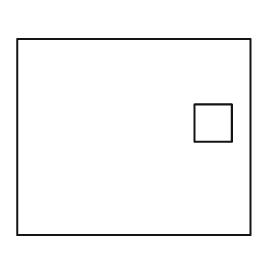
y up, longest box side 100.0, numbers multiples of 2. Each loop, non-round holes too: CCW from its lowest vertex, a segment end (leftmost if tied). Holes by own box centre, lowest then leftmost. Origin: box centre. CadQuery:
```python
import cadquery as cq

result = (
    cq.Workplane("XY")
    .moveTo(-50.0, -42.0)
    .lineTo(50.0, -42.0)
    .lineTo(50.0, 42.0)
    .lineTo(-50.0, 42.0)
    .close()
    .moveTo(26.0, -2.0)
    .lineTo(42.0, -2.0)
    .lineTo(42.0, 14.0)
    .lineTo(26.0, 14.0)
    .close()
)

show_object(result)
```